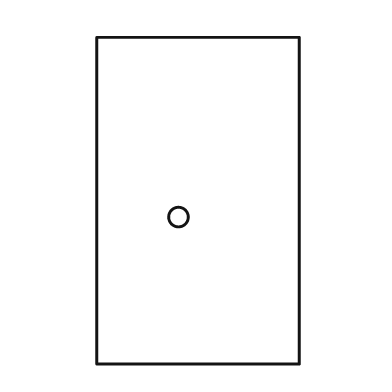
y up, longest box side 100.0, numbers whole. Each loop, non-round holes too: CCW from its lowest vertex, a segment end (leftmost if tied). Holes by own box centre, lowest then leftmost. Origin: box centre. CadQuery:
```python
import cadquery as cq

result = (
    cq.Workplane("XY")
    .moveTo(-31.0, -50.0)
    .lineTo(31.0, -50.0)
    .lineTo(31.0, 50.0)
    .lineTo(-31.0, 50.0)
    .close()
    .moveTo(-6.0, -5.0)
    .circle(3.0)
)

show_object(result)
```